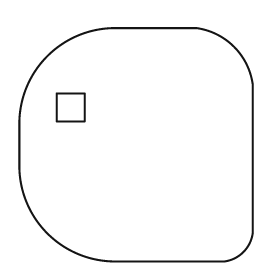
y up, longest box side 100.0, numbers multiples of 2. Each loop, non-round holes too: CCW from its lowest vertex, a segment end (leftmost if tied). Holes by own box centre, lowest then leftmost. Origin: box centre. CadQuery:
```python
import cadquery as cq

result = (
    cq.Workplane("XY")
    .moveTo(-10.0, -50.0)
    .lineTo(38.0, -50.0)
    .threePointArc((46.0, -46.0), (50.0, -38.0))
    .lineTo(50.0, 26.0)
    .threePointArc((42.0, 42.0), (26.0, 50.0))
    .lineTo(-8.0, 50.0)
    .threePointArc((-38.0, 38.0), (-50.0, 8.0))
    .lineTo(-50.0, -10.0)
    .threePointArc((-38.0, -38.0), (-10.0, -50.0))
    .close()
    .moveTo(-34.0, 10.0)
    .lineTo(-22.0, 10.0)
    .lineTo(-22.0, 22.0)
    .lineTo(-34.0, 22.0)
    .close()
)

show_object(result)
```